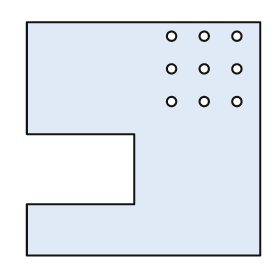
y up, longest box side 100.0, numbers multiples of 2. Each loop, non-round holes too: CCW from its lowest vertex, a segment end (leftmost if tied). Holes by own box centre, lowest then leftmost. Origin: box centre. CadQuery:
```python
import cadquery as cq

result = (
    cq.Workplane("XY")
    .moveTo(-50.0, -50.0)
    .lineTo(50.0, -50.0)
    .lineTo(50.0, 50.0)
    .lineTo(-50.0, 50.0)
    .lineTo(-50.0, 2.0)
    .lineTo(-4.0, 2.0)
    .lineTo(-4.0, -28.0)
    .lineTo(-50.0, -28.0)
    .close()
    .moveTo(12.0, 16.0)
    .circle(2.0)
    .moveTo(26.0, 16.0)
    .circle(2.0)
    .moveTo(40.0, 16.0)
    .circle(2.0)
    .moveTo(12.0, 30.0)
    .circle(2.0)
    .moveTo(26.0, 30.0)
    .circle(2.0)
    .moveTo(40.0, 30.0)
    .circle(2.0)
    .moveTo(12.0, 44.0)
    .circle(2.0)
    .moveTo(26.0, 44.0)
    .circle(2.0)
    .moveTo(40.0, 44.0)
    .circle(2.0)
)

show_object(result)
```